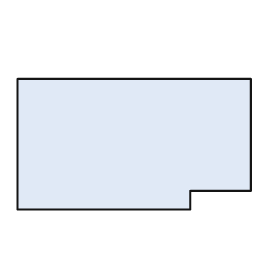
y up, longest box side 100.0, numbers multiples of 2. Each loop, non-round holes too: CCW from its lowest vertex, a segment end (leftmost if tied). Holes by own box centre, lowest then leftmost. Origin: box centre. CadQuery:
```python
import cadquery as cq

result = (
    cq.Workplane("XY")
    .moveTo(-50.0, -28.0)
    .lineTo(24.0, -28.0)
    .lineTo(24.0, -20.0)
    .lineTo(50.0, -20.0)
    .lineTo(50.0, 28.0)
    .lineTo(-50.0, 28.0)
    .close()
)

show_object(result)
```